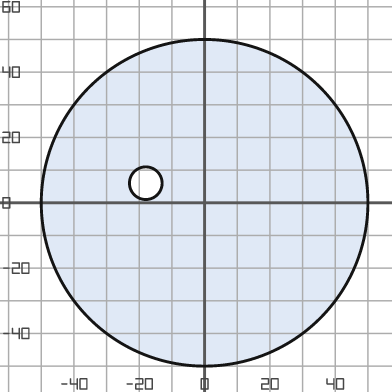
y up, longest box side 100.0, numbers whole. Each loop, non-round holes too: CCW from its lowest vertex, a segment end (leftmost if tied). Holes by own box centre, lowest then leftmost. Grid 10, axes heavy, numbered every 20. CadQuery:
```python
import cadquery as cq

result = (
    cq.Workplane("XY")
    .moveTo(0.0, 0.0)
    .circle(50.0)
    .moveTo(-18.0, 6.0)
    .circle(5.0)
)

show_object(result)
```